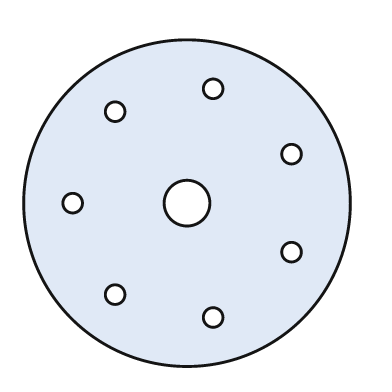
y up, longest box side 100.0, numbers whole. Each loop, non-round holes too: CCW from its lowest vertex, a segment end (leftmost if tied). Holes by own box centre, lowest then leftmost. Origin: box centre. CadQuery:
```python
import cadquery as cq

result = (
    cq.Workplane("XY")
    .moveTo(0.0, 0.0)
    .circle(50.0)
    .moveTo(8.0, -35.0)
    .circle(3.0)
    .moveTo(-22.0, -28.0)
    .circle(3.0)
    .moveTo(32.0, -15.0)
    .circle(3.0)
    .moveTo(-35.0, 0.0)
    .circle(3.0)
    .moveTo(0.0, 0.0)
    .circle(7.0)
    .moveTo(32.0, 15.0)
    .circle(3.0)
    .moveTo(-22.0, 28.0)
    .circle(3.0)
    .moveTo(8.0, 35.0)
    .circle(3.0)
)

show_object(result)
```